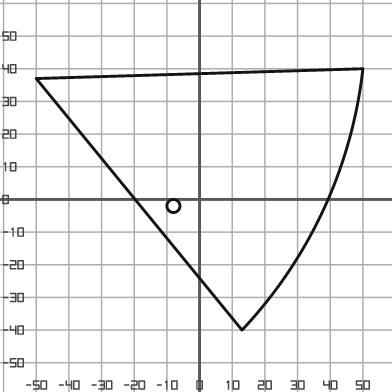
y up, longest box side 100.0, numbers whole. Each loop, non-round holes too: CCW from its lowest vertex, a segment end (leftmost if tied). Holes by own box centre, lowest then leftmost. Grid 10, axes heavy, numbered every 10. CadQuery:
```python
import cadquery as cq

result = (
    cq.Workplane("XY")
    .moveTo(13.0, -40.0)
    .threePointArc((38.0, -3.0), (50.0, 40.0))
    .lineTo(-50.0, 37.0)
    .close()
    .moveTo(-8.0, -2.0)
    .circle(2.0)
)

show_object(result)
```